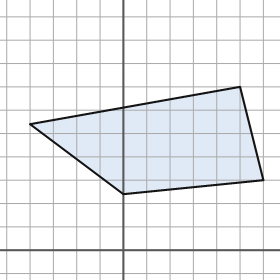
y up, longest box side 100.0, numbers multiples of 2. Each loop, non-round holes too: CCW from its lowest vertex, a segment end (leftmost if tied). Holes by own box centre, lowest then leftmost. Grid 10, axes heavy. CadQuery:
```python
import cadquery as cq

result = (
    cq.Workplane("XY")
    .moveTo(0.0, 24.0)
    .lineTo(60.0, 30.0)
    .lineTo(50.0, 70.0)
    .lineTo(-40.0, 54.0)
    .close()
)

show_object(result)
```